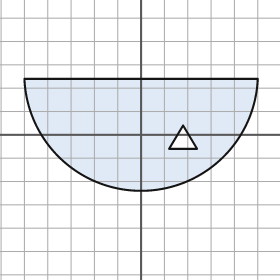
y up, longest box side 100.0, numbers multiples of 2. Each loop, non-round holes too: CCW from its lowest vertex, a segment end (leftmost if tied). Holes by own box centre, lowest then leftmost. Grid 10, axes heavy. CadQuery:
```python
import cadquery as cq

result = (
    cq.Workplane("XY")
    .moveTo(-50.0, 24.0)
    .threePointArc((0.0, -24.0), (50.0, 24.0))
    .close()
    .moveTo(12.0, -6.0)
    .lineTo(24.0, -6.0)
    .lineTo(18.0, 4.0)
    .close()
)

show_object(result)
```